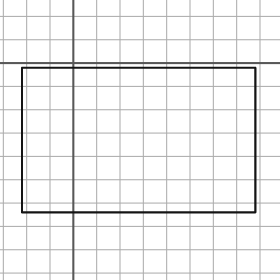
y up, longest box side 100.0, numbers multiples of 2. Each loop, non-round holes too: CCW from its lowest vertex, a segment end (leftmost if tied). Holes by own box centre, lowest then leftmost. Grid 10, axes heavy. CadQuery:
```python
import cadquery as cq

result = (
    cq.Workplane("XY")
    .moveTo(-22.0, -64.0)
    .lineTo(78.0, -64.0)
    .lineTo(78.0, -2.0)
    .lineTo(-22.0, -2.0)
    .close()
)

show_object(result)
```